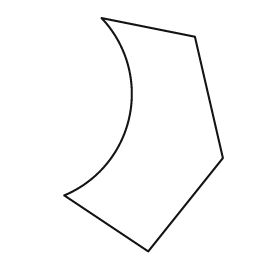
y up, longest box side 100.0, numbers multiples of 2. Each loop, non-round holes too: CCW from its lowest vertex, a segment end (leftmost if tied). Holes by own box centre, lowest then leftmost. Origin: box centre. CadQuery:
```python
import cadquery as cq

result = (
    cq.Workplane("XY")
    .moveTo(2.0, -50.0)
    .lineTo(34.0, -10.0)
    .lineTo(22.0, 42.0)
    .lineTo(-18.0, 50.0)
    .threePointArc((-6.0, 8.0), (-34.0, -26.0))
    .close()
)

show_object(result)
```